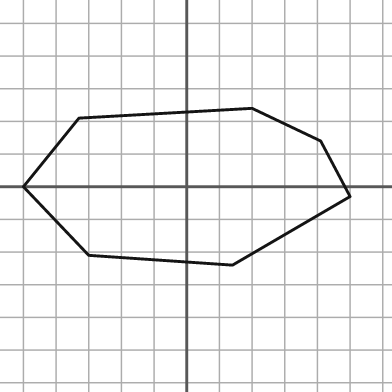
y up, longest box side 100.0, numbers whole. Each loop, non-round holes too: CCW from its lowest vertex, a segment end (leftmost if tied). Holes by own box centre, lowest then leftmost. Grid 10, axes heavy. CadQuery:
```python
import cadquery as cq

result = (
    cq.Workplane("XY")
    .moveTo(14.0, -24.0)
    .lineTo(50.0, -3.0)
    .lineTo(41.0, 14.0)
    .lineTo(20.0, 24.0)
    .lineTo(-33.0, 21.0)
    .lineTo(-50.0, 0.0)
    .lineTo(-30.0, -21.0)
    .close()
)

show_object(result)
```